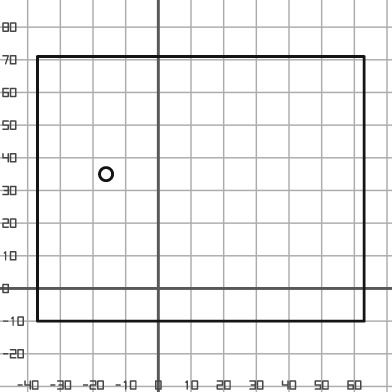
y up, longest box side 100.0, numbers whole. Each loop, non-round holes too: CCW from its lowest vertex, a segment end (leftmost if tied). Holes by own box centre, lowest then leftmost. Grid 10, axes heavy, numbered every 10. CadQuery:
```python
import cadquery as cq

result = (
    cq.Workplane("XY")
    .moveTo(-37.0, -10.0)
    .lineTo(63.0, -10.0)
    .lineTo(63.0, 71.0)
    .lineTo(-37.0, 71.0)
    .close()
    .moveTo(-16.0, 35.0)
    .circle(2.0)
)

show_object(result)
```